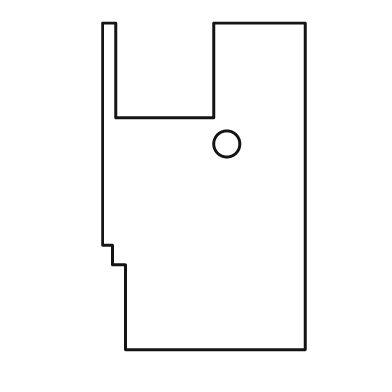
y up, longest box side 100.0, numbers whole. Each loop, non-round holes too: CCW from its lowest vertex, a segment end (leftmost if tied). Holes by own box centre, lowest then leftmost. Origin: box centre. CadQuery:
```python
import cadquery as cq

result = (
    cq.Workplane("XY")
    .moveTo(-24.0, -50.0)
    .lineTo(31.0, -50.0)
    .lineTo(31.0, 50.0)
    .lineTo(3.0, 50.0)
    .lineTo(3.0, 21.0)
    .lineTo(-27.0, 21.0)
    .lineTo(-27.0, 50.0)
    .lineTo(-31.0, 50.0)
    .lineTo(-31.0, -18.0)
    .lineTo(-28.0, -18.0)
    .lineTo(-28.0, -24.0)
    .lineTo(-24.0, -24.0)
    .close()
    .moveTo(7.0, 13.0)
    .circle(4.0)
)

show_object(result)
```